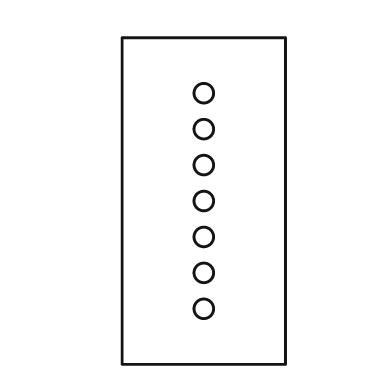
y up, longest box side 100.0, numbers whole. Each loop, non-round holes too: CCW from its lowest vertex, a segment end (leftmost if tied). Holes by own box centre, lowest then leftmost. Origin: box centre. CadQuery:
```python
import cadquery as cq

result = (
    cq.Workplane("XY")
    .moveTo(-25.0, -50.0)
    .lineTo(25.0, -50.0)
    .lineTo(25.0, 50.0)
    .lineTo(-25.0, 50.0)
    .close()
    .moveTo(0.0, -33.0)
    .circle(3.0)
    .moveTo(0.0, -22.0)
    .circle(3.0)
    .moveTo(0.0, -11.0)
    .circle(3.0)
    .moveTo(0.0, 0.0)
    .circle(3.0)
    .moveTo(0.0, 11.0)
    .circle(3.0)
    .moveTo(0.0, 22.0)
    .circle(3.0)
    .moveTo(0.0, 33.0)
    .circle(3.0)
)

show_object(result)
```